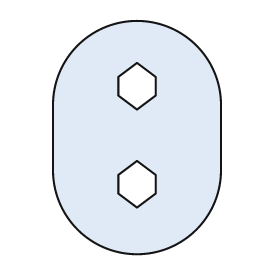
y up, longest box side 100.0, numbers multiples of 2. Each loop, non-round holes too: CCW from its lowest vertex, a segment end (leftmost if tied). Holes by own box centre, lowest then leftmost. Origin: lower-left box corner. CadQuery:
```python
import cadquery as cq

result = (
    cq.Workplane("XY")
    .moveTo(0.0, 36.0)
    .threePointArc((36.0, 0.0), (72.0, 36.0))
    .lineTo(72.0, 64.0)
    .threePointArc((36.0, 100.0), (0.0, 64.0))
    .close()
    .moveTo(36.0, 20.0)
    .lineTo(44.0, 26.0)
    .lineTo(44.0, 34.0)
    .lineTo(36.0, 40.0)
    .lineTo(28.0, 34.0)
    .lineTo(28.0, 26.0)
    .close()
    .moveTo(36.0, 62.0)
    .lineTo(44.0, 68.0)
    .lineTo(44.0, 76.0)
    .lineTo(36.0, 82.0)
    .lineTo(28.0, 76.0)
    .lineTo(28.0, 68.0)
    .close()
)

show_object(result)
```